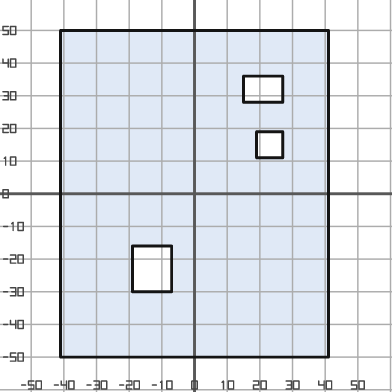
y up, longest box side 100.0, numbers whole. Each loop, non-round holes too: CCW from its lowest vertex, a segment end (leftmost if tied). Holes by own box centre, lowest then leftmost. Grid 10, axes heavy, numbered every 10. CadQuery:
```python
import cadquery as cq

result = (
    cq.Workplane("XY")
    .moveTo(-41.0, -50.0)
    .lineTo(41.0, -50.0)
    .lineTo(41.0, 50.0)
    .lineTo(-41.0, 50.0)
    .close()
    .moveTo(-19.0, -30.0)
    .lineTo(-7.0, -30.0)
    .lineTo(-7.0, -16.0)
    .lineTo(-19.0, -16.0)
    .close()
    .moveTo(19.0, 11.0)
    .lineTo(27.0, 11.0)
    .lineTo(27.0, 19.0)
    .lineTo(19.0, 19.0)
    .close()
    .moveTo(15.0, 28.0)
    .lineTo(27.0, 28.0)
    .lineTo(27.0, 36.0)
    .lineTo(15.0, 36.0)
    .close()
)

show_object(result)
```